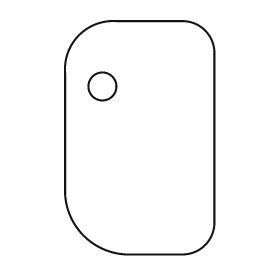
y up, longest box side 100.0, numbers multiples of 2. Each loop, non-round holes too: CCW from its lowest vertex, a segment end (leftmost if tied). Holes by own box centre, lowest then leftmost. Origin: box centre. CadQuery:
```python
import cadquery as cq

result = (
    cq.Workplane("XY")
    .moveTo(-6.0, -50.0)
    .lineTo(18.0, -50.0)
    .threePointArc((28.0, -46.0), (32.0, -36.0))
    .lineTo(32.0, 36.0)
    .threePointArc((28.0, 46.0), (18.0, 50.0))
    .lineTo(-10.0, 50.0)
    .threePointArc((-26.0, 44.0), (-32.0, 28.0))
    .lineTo(-32.0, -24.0)
    .threePointArc((-24.0, -42.0), (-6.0, -50.0))
    .close()
    .moveTo(-16.0, 22.0)
    .circle(6.0)
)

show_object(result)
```